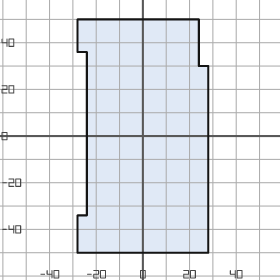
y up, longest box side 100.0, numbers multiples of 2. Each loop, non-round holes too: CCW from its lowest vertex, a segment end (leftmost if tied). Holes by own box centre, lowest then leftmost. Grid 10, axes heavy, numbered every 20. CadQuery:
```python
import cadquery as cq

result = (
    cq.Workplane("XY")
    .moveTo(-28.0, -50.0)
    .lineTo(28.0, -50.0)
    .lineTo(28.0, 30.0)
    .lineTo(24.0, 30.0)
    .lineTo(24.0, 50.0)
    .lineTo(-28.0, 50.0)
    .lineTo(-28.0, 36.0)
    .lineTo(-24.0, 36.0)
    .lineTo(-24.0, -34.0)
    .lineTo(-28.0, -34.0)
    .close()
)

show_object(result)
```